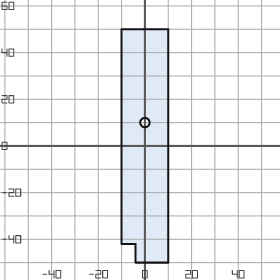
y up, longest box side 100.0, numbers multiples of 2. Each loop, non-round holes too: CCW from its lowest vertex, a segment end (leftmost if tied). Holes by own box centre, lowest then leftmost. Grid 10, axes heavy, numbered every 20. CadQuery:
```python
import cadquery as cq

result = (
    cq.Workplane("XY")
    .moveTo(-4.0, -50.0)
    .lineTo(10.0, -50.0)
    .lineTo(10.0, 50.0)
    .lineTo(-10.0, 50.0)
    .lineTo(-10.0, -42.0)
    .lineTo(-4.0, -42.0)
    .close()
    .moveTo(0.0, 10.0)
    .circle(2.0)
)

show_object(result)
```